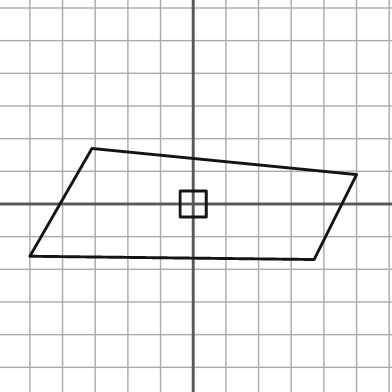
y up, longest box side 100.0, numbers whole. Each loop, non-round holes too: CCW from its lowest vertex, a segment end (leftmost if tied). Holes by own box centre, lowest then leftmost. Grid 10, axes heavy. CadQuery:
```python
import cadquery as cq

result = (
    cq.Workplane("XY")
    .moveTo(37.0, -17.0)
    .lineTo(50.0, 9.0)
    .lineTo(-31.0, 17.0)
    .lineTo(-50.0, -16.0)
    .close()
    .moveTo(-4.0, -4.0)
    .lineTo(4.0, -4.0)
    .lineTo(4.0, 4.0)
    .lineTo(-4.0, 4.0)
    .close()
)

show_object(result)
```